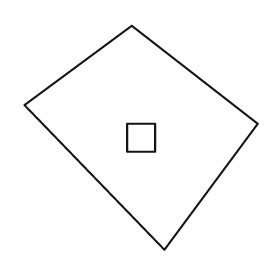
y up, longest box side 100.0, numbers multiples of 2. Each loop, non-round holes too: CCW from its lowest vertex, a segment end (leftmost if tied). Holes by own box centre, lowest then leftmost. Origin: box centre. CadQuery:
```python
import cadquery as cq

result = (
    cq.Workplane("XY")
    .moveTo(10.0, -48.0)
    .lineTo(50.0, 6.0)
    .lineTo(-4.0, 48.0)
    .lineTo(-50.0, 14.0)
    .close()
    .moveTo(-6.0, -6.0)
    .lineTo(6.0, -6.0)
    .lineTo(6.0, 6.0)
    .lineTo(-6.0, 6.0)
    .close()
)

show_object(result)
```